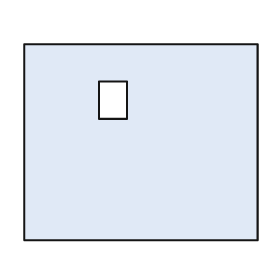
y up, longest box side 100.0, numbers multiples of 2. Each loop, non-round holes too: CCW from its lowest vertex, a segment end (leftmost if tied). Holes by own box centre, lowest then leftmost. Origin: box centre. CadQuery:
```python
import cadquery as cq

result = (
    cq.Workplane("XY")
    .moveTo(-50.0, -42.0)
    .lineTo(50.0, -42.0)
    .lineTo(50.0, 42.0)
    .lineTo(-50.0, 42.0)
    .close()
    .moveTo(-18.0, 10.0)
    .lineTo(-6.0, 10.0)
    .lineTo(-6.0, 26.0)
    .lineTo(-18.0, 26.0)
    .close()
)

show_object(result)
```